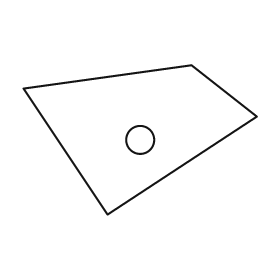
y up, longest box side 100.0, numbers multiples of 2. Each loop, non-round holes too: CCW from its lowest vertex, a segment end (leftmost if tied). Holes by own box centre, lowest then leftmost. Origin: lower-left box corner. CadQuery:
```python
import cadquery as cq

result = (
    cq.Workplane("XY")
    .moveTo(36.0, 0.0)
    .lineTo(100.0, 42.0)
    .lineTo(72.0, 64.0)
    .lineTo(0.0, 54.0)
    .close()
    .moveTo(50.0, 32.0)
    .circle(6.0)
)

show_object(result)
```